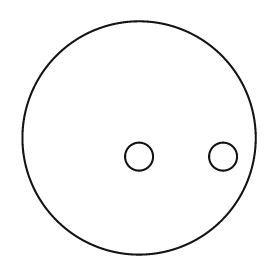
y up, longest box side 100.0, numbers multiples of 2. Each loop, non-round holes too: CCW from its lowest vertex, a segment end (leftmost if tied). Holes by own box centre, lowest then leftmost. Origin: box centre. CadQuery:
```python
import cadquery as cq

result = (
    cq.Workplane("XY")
    .moveTo(0.0, 0.0)
    .circle(50.0)
    .moveTo(0.0, -8.0)
    .circle(6.0)
    .moveTo(36.0, -8.0)
    .circle(6.0)
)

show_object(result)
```